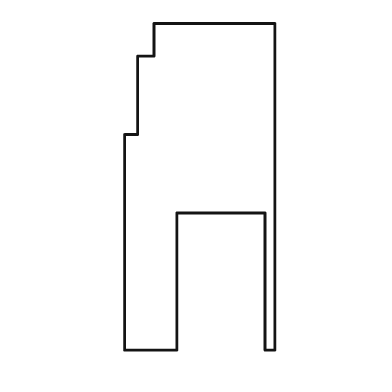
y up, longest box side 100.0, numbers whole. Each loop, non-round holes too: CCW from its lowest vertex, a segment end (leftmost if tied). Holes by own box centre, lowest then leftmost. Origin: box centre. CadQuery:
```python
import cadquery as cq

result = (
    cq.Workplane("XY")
    .moveTo(-23.0, -50.0)
    .lineTo(-7.0, -50.0)
    .lineTo(-7.0, -8.0)
    .lineTo(20.0, -8.0)
    .lineTo(20.0, -50.0)
    .lineTo(23.0, -50.0)
    .lineTo(23.0, 50.0)
    .lineTo(-14.0, 50.0)
    .lineTo(-14.0, 40.0)
    .lineTo(-19.0, 40.0)
    .lineTo(-19.0, 16.0)
    .lineTo(-23.0, 16.0)
    .close()
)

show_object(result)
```